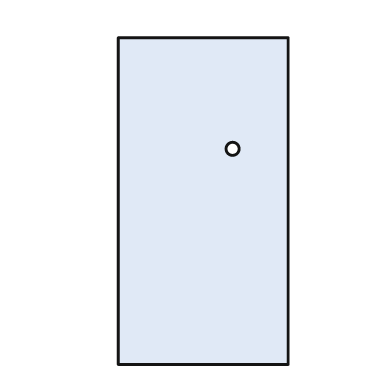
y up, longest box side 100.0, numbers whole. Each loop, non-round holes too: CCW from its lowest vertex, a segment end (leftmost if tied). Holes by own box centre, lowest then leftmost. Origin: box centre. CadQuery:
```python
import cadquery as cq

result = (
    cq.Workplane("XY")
    .moveTo(-26.0, -50.0)
    .lineTo(26.0, -50.0)
    .lineTo(26.0, 50.0)
    .lineTo(-26.0, 50.0)
    .close()
    .moveTo(9.0, 16.0)
    .circle(2.0)
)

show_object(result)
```